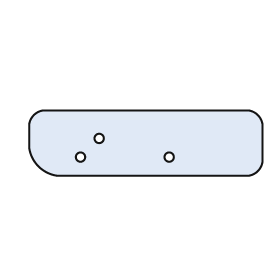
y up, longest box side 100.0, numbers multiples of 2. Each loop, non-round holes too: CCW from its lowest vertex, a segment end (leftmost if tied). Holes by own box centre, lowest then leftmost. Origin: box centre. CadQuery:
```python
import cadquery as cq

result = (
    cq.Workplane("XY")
    .moveTo(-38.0, -14.0)
    .lineTo(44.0, -14.0)
    .threePointArc((48.0, -12.0), (50.0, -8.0))
    .lineTo(50.0, 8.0)
    .threePointArc((48.0, 12.0), (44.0, 14.0))
    .lineTo(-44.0, 14.0)
    .threePointArc((-48.0, 12.0), (-50.0, 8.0))
    .lineTo(-50.0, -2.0)
    .threePointArc((-46.0, -10.0), (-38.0, -14.0))
    .close()
    .moveTo(-28.0, -6.0)
    .circle(2.0)
    .moveTo(10.0, -6.0)
    .circle(2.0)
    .moveTo(-20.0, 2.0)
    .circle(2.0)
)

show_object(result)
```